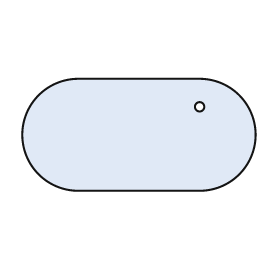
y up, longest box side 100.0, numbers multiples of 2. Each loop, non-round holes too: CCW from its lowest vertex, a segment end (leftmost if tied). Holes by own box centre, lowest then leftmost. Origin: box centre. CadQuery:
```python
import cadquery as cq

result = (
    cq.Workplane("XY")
    .moveTo(-26.0, -24.0)
    .lineTo(26.0, -24.0)
    .threePointArc((50.0, 0.0), (26.0, 24.0))
    .lineTo(-26.0, 24.0)
    .threePointArc((-50.0, 0.0), (-26.0, -24.0))
    .close()
    .moveTo(26.0, 12.0)
    .circle(2.0)
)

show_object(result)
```